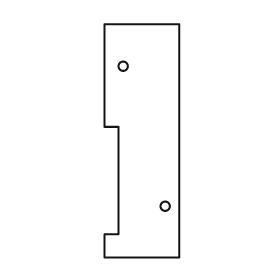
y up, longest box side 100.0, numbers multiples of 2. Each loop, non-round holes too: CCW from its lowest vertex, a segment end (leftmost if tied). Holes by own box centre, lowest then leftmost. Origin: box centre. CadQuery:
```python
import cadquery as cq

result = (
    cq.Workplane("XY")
    .moveTo(-16.0, -50.0)
    .lineTo(16.0, -50.0)
    .lineTo(16.0, 50.0)
    .lineTo(-16.0, 50.0)
    .lineTo(-16.0, 6.0)
    .lineTo(-10.0, 6.0)
    .lineTo(-10.0, -40.0)
    .lineTo(-16.0, -40.0)
    .close()
    .moveTo(10.0, -28.0)
    .circle(2.0)
    .moveTo(-8.0, 32.0)
    .circle(2.0)
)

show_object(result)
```